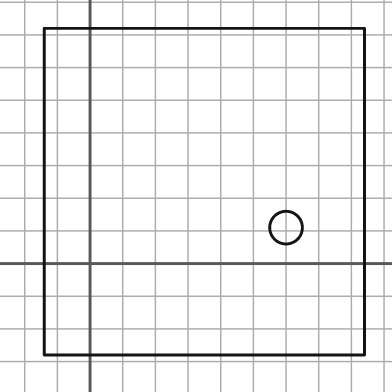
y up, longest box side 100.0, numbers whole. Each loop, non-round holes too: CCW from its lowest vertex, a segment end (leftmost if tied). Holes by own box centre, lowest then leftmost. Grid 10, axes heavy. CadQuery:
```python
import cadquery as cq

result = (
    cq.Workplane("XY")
    .moveTo(-14.0, -28.0)
    .lineTo(84.0, -28.0)
    .lineTo(84.0, 72.0)
    .lineTo(-14.0, 72.0)
    .close()
    .moveTo(60.0, 11.0)
    .circle(5.0)
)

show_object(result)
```